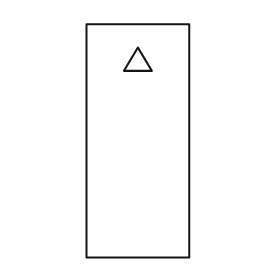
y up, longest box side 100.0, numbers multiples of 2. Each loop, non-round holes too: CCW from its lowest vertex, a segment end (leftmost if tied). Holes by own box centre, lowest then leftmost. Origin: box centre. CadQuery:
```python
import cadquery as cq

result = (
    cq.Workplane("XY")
    .moveTo(-22.0, -50.0)
    .lineTo(22.0, -50.0)
    .lineTo(22.0, 50.0)
    .lineTo(-22.0, 50.0)
    .close()
    .moveTo(-6.0, 30.0)
    .lineTo(6.0, 30.0)
    .lineTo(0.0, 40.0)
    .close()
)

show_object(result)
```